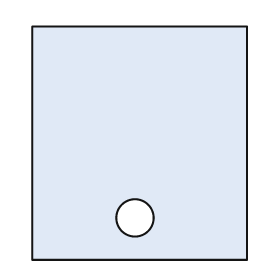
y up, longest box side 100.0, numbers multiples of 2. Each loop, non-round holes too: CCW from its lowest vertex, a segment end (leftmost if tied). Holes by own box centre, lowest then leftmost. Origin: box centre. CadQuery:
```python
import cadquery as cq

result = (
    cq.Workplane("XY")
    .moveTo(-46.0, -50.0)
    .lineTo(46.0, -50.0)
    .lineTo(46.0, 50.0)
    .lineTo(-46.0, 50.0)
    .close()
    .moveTo(-2.0, -32.0)
    .circle(8.0)
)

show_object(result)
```